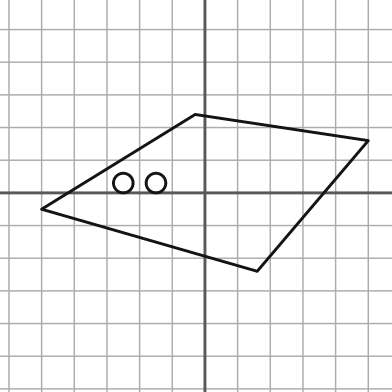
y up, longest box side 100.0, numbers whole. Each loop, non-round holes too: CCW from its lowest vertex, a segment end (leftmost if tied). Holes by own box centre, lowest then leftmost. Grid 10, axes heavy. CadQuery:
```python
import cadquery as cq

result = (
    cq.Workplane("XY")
    .moveTo(16.0, -24.0)
    .lineTo(50.0, 16.0)
    .lineTo(-3.0, 24.0)
    .lineTo(-50.0, -5.0)
    .close()
    .moveTo(-25.0, 3.0)
    .circle(3.0)
    .moveTo(-15.0, 3.0)
    .circle(3.0)
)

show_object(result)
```